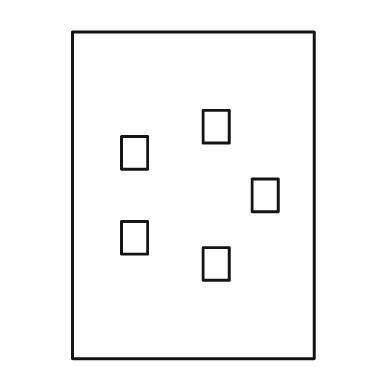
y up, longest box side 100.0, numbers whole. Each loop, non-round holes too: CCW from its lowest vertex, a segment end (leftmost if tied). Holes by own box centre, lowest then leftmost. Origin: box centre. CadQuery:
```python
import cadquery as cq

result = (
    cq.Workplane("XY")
    .moveTo(-37.0, -50.0)
    .lineTo(37.0, -50.0)
    .lineTo(37.0, 50.0)
    .lineTo(-37.0, 50.0)
    .close()
    .moveTo(3.0, -26.0)
    .lineTo(11.0, -26.0)
    .lineTo(11.0, -16.0)
    .lineTo(3.0, -16.0)
    .close()
    .moveTo(-22.0, -18.0)
    .lineTo(-14.0, -18.0)
    .lineTo(-14.0, -8.0)
    .lineTo(-22.0, -8.0)
    .close()
    .moveTo(18.0, -5.0)
    .lineTo(26.0, -5.0)
    .lineTo(26.0, 5.0)
    .lineTo(18.0, 5.0)
    .close()
    .moveTo(-22.0, 8.0)
    .lineTo(-14.0, 8.0)
    .lineTo(-14.0, 18.0)
    .lineTo(-22.0, 18.0)
    .close()
    .moveTo(3.0, 16.0)
    .lineTo(11.0, 16.0)
    .lineTo(11.0, 26.0)
    .lineTo(3.0, 26.0)
    .close()
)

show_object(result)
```